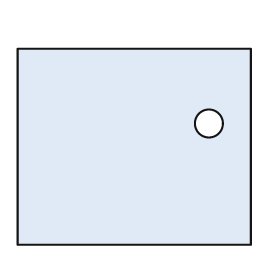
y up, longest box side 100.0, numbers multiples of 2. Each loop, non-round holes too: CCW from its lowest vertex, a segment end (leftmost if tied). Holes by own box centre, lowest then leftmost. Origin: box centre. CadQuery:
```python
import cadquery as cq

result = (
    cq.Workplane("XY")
    .moveTo(-50.0, -42.0)
    .lineTo(50.0, -42.0)
    .lineTo(50.0, 42.0)
    .lineTo(-50.0, 42.0)
    .close()
    .moveTo(32.0, 10.0)
    .circle(6.0)
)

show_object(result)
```